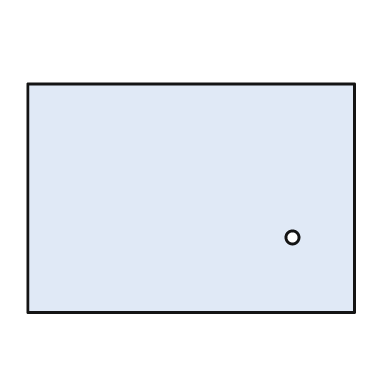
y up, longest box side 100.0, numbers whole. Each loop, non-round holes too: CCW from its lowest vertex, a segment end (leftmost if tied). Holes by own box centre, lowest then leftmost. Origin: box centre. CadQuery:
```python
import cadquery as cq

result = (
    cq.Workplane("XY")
    .moveTo(-50.0, -35.0)
    .lineTo(50.0, -35.0)
    .lineTo(50.0, 35.0)
    .lineTo(-50.0, 35.0)
    .close()
    .moveTo(31.0, -12.0)
    .circle(2.0)
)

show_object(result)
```